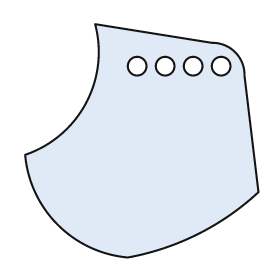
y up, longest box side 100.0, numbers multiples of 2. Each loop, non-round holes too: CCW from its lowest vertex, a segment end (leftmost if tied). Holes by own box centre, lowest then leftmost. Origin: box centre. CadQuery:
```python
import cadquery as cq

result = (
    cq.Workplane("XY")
    .moveTo(-6.0, -50.0)
    .threePointArc((24.0, -40.0), (50.0, -22.0))
    .lineTo(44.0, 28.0)
    .threePointArc((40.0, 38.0), (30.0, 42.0))
    .lineTo(-20.0, 50.0)
    .threePointArc((-24.0, 16.0), (-50.0, -6.0))
    .threePointArc((-36.0, -36.0), (-6.0, -50.0))
    .close()
    .moveTo(-2.0, 32.0)
    .circle(4.0)
    .moveTo(10.0, 32.0)
    .circle(4.0)
    .moveTo(22.0, 32.0)
    .circle(4.0)
    .moveTo(34.0, 32.0)
    .circle(4.0)
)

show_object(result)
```